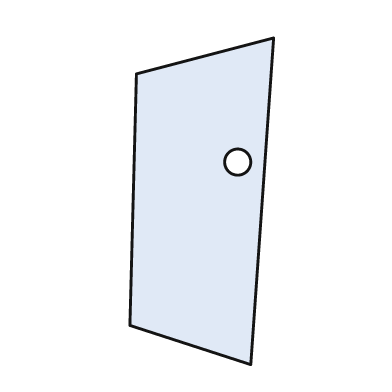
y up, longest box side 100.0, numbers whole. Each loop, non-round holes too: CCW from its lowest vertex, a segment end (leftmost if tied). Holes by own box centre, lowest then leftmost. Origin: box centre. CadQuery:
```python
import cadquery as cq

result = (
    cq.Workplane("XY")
    .moveTo(15.0, -50.0)
    .lineTo(22.0, 50.0)
    .lineTo(-20.0, 39.0)
    .lineTo(-22.0, -38.0)
    .close()
    .moveTo(11.0, 12.0)
    .circle(4.0)
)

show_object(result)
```